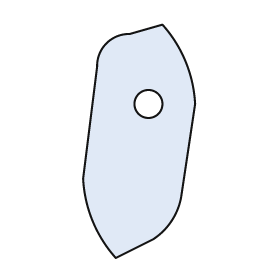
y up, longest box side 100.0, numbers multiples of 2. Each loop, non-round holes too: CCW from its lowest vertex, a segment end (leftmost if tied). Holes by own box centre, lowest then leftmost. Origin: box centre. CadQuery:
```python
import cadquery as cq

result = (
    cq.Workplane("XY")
    .moveTo(-10.0, -50.0)
    .lineTo(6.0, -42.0)
    .threePointArc((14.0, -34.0), (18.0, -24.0))
    .lineTo(24.0, 16.0)
    .threePointArc((20.0, 34.0), (10.0, 50.0))
    .lineTo(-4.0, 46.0)
    .threePointArc((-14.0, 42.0), (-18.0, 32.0))
    .lineTo(-24.0, -16.0)
    .threePointArc((-20.0, -34.0), (-10.0, -50.0))
    .close()
    .moveTo(4.0, 16.0)
    .circle(6.0)
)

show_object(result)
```